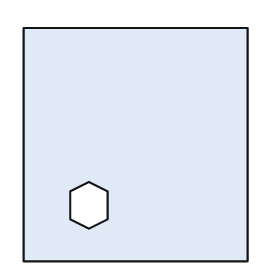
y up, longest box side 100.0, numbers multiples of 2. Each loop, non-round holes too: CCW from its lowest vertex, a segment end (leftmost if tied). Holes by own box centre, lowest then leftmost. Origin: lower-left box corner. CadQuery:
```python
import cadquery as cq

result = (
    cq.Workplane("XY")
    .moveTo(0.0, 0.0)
    .lineTo(96.0, 0.0)
    .lineTo(96.0, 100.0)
    .lineTo(0.0, 100.0)
    .close()
    .moveTo(28.0, 14.0)
    .lineTo(36.0, 18.0)
    .lineTo(36.0, 30.0)
    .lineTo(28.0, 34.0)
    .lineTo(20.0, 30.0)
    .lineTo(20.0, 18.0)
    .close()
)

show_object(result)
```